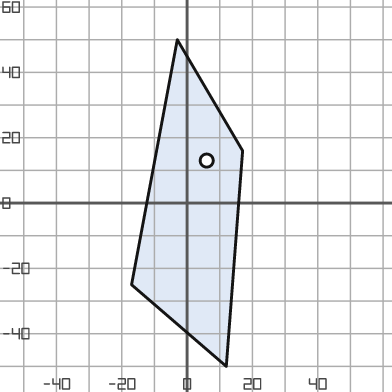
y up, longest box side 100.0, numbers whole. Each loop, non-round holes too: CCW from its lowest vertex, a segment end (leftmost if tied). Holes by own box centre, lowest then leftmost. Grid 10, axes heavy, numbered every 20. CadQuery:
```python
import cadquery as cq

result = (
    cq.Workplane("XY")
    .moveTo(12.0, -50.0)
    .lineTo(17.0, 16.0)
    .lineTo(-3.0, 50.0)
    .lineTo(-17.0, -25.0)
    .close()
    .moveTo(6.0, 13.0)
    .circle(2.0)
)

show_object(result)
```